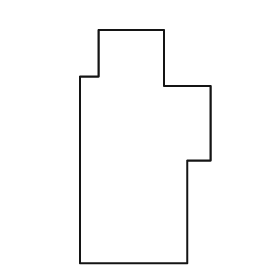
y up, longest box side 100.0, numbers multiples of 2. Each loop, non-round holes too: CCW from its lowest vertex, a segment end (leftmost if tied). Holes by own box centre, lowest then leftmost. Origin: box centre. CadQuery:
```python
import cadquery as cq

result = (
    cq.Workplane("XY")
    .moveTo(-28.0, -50.0)
    .lineTo(18.0, -50.0)
    .lineTo(18.0, -6.0)
    .lineTo(28.0, -6.0)
    .lineTo(28.0, 26.0)
    .lineTo(8.0, 26.0)
    .lineTo(8.0, 50.0)
    .lineTo(-20.0, 50.0)
    .lineTo(-20.0, 30.0)
    .lineTo(-28.0, 30.0)
    .close()
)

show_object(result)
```